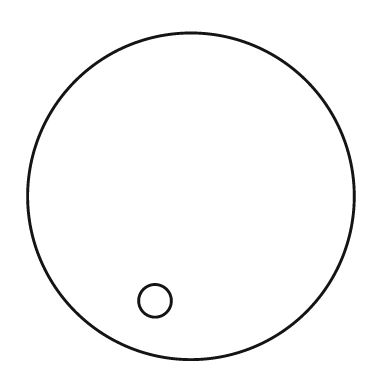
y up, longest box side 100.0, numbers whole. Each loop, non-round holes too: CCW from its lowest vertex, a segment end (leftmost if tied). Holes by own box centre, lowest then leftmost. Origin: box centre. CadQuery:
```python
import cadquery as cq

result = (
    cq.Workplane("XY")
    .moveTo(0.0, 0.0)
    .circle(50.0)
    .moveTo(-11.0, -32.0)
    .circle(5.0)
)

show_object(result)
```